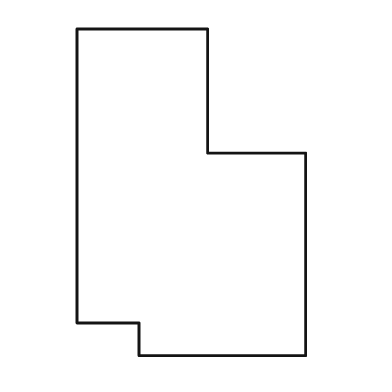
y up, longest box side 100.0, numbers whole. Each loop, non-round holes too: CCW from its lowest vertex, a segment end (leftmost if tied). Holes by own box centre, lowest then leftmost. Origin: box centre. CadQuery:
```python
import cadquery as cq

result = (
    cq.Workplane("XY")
    .moveTo(-16.0, -50.0)
    .lineTo(35.0, -50.0)
    .lineTo(35.0, 12.0)
    .lineTo(5.0, 12.0)
    .lineTo(5.0, 50.0)
    .lineTo(-35.0, 50.0)
    .lineTo(-35.0, -40.0)
    .lineTo(-16.0, -40.0)
    .close()
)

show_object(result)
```